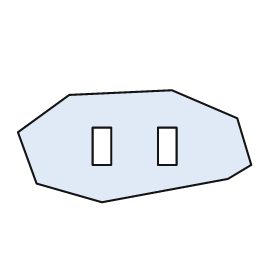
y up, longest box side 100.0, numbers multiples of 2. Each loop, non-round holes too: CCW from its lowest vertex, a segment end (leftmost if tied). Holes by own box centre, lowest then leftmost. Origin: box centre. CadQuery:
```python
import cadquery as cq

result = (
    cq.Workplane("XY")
    .moveTo(-14.0, -24.0)
    .lineTo(40.0, -14.0)
    .lineTo(50.0, -8.0)
    .lineTo(44.0, 12.0)
    .lineTo(16.0, 24.0)
    .lineTo(-28.0, 22.0)
    .lineTo(-50.0, 6.0)
    .lineTo(-42.0, -16.0)
    .close()
    .moveTo(-18.0, -8.0)
    .lineTo(-10.0, -8.0)
    .lineTo(-10.0, 8.0)
    .lineTo(-18.0, 8.0)
    .close()
    .moveTo(10.0, -8.0)
    .lineTo(18.0, -8.0)
    .lineTo(18.0, 8.0)
    .lineTo(10.0, 8.0)
    .close()
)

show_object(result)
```